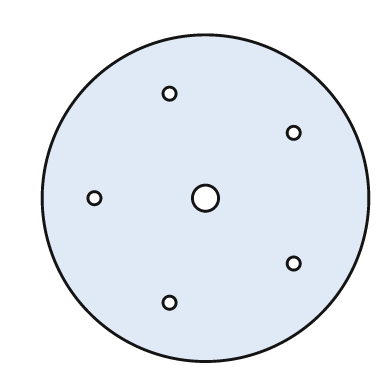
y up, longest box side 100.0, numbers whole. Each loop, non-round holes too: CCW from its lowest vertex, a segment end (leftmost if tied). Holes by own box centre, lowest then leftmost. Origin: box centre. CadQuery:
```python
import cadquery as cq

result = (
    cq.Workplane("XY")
    .moveTo(0.0, 0.0)
    .circle(50.0)
    .moveTo(-11.0, -32.0)
    .circle(2.0)
    .moveTo(27.0, -20.0)
    .circle(2.0)
    .moveTo(-34.0, 0.0)
    .circle(2.0)
    .moveTo(0.0, 0.0)
    .circle(4.0)
    .moveTo(27.0, 20.0)
    .circle(2.0)
    .moveTo(-11.0, 32.0)
    .circle(2.0)
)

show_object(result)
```